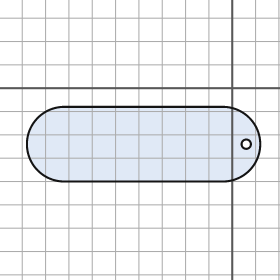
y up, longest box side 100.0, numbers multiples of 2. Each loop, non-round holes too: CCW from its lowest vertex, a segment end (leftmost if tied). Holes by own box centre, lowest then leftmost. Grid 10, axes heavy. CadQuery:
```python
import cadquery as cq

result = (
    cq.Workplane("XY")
    .moveTo(-72.0, -40.0)
    .lineTo(-4.0, -40.0)
    .threePointArc((12.0, -24.0), (-4.0, -8.0))
    .lineTo(-72.0, -8.0)
    .threePointArc((-88.0, -24.0), (-72.0, -40.0))
    .close()
    .moveTo(6.0, -24.0)
    .circle(2.0)
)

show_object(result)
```